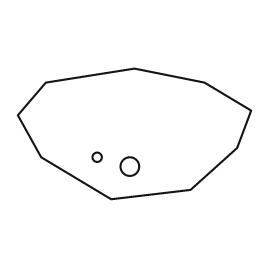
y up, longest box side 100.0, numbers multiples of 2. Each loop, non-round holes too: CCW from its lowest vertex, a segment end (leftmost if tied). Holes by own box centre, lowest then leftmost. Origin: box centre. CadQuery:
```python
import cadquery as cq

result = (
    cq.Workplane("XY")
    .moveTo(-10.0, -28.0)
    .lineTo(24.0, -24.0)
    .lineTo(44.0, -6.0)
    .lineTo(50.0, 10.0)
    .lineTo(30.0, 22.0)
    .lineTo(0.0, 28.0)
    .lineTo(-38.0, 22.0)
    .lineTo(-50.0, 8.0)
    .lineTo(-40.0, -10.0)
    .close()
    .moveTo(-2.0, -14.0)
    .circle(4.0)
    .moveTo(-16.0, -10.0)
    .circle(2.0)
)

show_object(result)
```